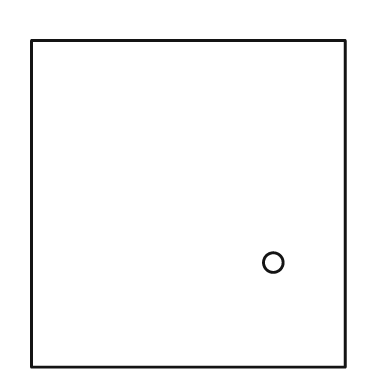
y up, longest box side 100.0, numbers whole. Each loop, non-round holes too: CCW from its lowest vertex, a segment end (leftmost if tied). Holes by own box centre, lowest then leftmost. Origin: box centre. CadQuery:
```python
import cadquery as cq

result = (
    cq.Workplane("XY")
    .moveTo(-48.0, -50.0)
    .lineTo(48.0, -50.0)
    .lineTo(48.0, 50.0)
    .lineTo(-48.0, 50.0)
    .close()
    .moveTo(26.0, -18.0)
    .circle(3.0)
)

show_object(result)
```